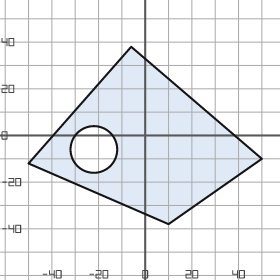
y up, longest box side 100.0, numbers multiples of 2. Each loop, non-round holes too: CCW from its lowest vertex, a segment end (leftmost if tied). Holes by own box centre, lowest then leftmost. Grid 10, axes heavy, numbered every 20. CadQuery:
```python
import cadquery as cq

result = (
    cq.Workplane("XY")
    .moveTo(10.0, -38.0)
    .lineTo(50.0, -10.0)
    .lineTo(-6.0, 38.0)
    .lineTo(-50.0, -12.0)
    .close()
    .moveTo(-22.0, -6.0)
    .circle(10.0)
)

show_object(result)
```